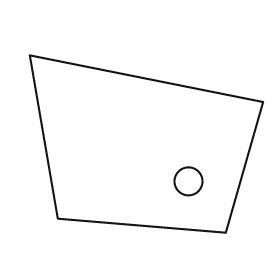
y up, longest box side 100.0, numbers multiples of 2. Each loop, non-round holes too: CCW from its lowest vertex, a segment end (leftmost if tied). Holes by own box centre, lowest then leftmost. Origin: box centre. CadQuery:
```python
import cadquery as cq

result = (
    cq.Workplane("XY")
    .moveTo(34.0, -38.0)
    .lineTo(50.0, 18.0)
    .lineTo(-50.0, 38.0)
    .lineTo(-38.0, -32.0)
    .close()
    .moveTo(18.0, -16.0)
    .circle(6.0)
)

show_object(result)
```